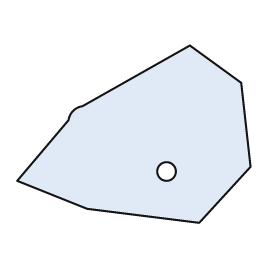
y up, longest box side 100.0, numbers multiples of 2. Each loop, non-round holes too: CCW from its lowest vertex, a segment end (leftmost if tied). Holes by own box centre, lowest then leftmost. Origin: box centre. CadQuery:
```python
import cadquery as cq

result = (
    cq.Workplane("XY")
    .moveTo(28.0, -38.0)
    .lineTo(50.0, -14.0)
    .lineTo(46.0, 22.0)
    .lineTo(24.0, 38.0)
    .lineTo(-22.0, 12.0)
    .threePointArc((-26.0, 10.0), (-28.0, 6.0))
    .lineTo(-50.0, -20.0)
    .lineTo(-20.0, -32.0)
    .close()
    .moveTo(14.0, -16.0)
    .circle(4.0)
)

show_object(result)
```